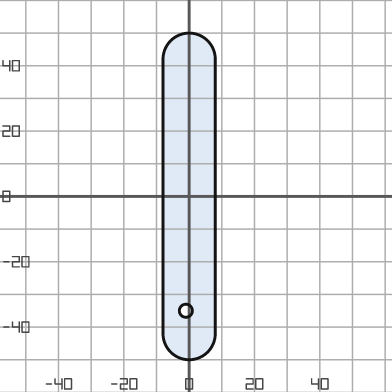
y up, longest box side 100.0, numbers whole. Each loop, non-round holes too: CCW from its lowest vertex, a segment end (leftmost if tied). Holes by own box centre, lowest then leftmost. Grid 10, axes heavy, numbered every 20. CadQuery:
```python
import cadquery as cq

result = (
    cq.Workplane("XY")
    .moveTo(-8.0, -42.0)
    .threePointArc((0.0, -50.0), (8.0, -42.0))
    .lineTo(8.0, 42.0)
    .threePointArc((0.0, 50.0), (-8.0, 42.0))
    .close()
    .moveTo(-1.0, -35.0)
    .circle(2.0)
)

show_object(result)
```